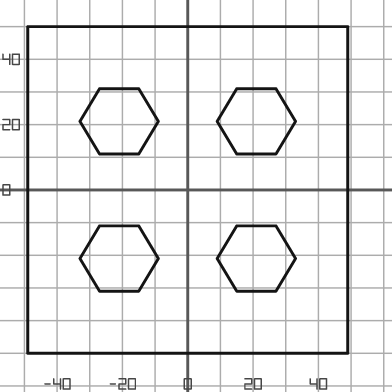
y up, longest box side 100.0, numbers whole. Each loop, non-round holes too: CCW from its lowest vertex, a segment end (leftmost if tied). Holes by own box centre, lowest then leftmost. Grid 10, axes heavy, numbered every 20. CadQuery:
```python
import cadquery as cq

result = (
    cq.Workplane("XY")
    .moveTo(-49.0, -50.0)
    .lineTo(49.0, -50.0)
    .lineTo(49.0, 50.0)
    .lineTo(-49.0, 50.0)
    .close()
    .moveTo(-27.0, -31.0)
    .lineTo(-15.0, -31.0)
    .lineTo(-9.0, -21.0)
    .lineTo(-15.0, -11.0)
    .lineTo(-27.0, -11.0)
    .lineTo(-33.0, -21.0)
    .close()
    .moveTo(15.0, -31.0)
    .lineTo(27.0, -31.0)
    .lineTo(33.0, -21.0)
    .lineTo(27.0, -11.0)
    .lineTo(15.0, -11.0)
    .lineTo(9.0, -21.0)
    .close()
    .moveTo(-27.0, 11.0)
    .lineTo(-15.0, 11.0)
    .lineTo(-9.0, 21.0)
    .lineTo(-15.0, 31.0)
    .lineTo(-27.0, 31.0)
    .lineTo(-33.0, 21.0)
    .close()
    .moveTo(15.0, 11.0)
    .lineTo(27.0, 11.0)
    .lineTo(33.0, 21.0)
    .lineTo(27.0, 31.0)
    .lineTo(15.0, 31.0)
    .lineTo(9.0, 21.0)
    .close()
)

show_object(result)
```